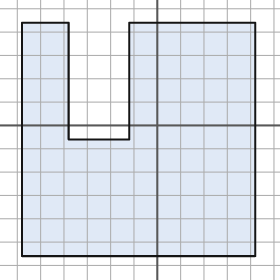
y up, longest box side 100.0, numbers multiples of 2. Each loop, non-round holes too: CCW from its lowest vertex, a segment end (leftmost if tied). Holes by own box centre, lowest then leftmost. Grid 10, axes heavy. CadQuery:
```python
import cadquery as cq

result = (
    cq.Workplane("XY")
    .moveTo(-58.0, -56.0)
    .lineTo(42.0, -56.0)
    .lineTo(42.0, 44.0)
    .lineTo(-12.0, 44.0)
    .lineTo(-12.0, -6.0)
    .lineTo(-38.0, -6.0)
    .lineTo(-38.0, 44.0)
    .lineTo(-58.0, 44.0)
    .close()
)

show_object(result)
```